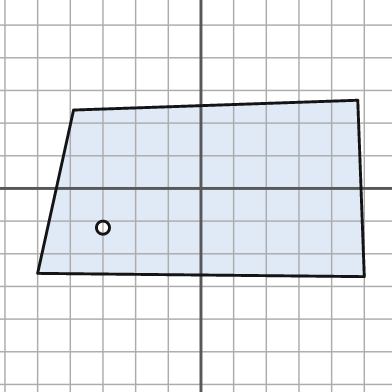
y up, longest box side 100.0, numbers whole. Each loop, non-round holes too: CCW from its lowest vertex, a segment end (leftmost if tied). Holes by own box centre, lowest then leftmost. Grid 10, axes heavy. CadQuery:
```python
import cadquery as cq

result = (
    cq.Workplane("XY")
    .moveTo(50.0, -27.0)
    .lineTo(48.0, 27.0)
    .lineTo(-39.0, 24.0)
    .lineTo(-50.0, -26.0)
    .close()
    .moveTo(-30.0, -12.0)
    .circle(2.0)
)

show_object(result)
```